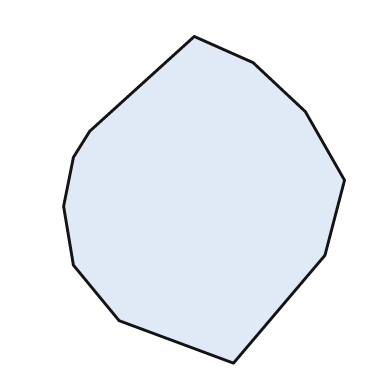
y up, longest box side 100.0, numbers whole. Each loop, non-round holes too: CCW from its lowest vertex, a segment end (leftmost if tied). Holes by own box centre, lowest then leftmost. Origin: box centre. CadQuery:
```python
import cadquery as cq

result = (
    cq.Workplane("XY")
    .moveTo(9.0, -50.0)
    .lineTo(37.0, -17.0)
    .lineTo(43.0, 6.0)
    .lineTo(31.0, 27.0)
    .lineTo(15.0, 42.0)
    .lineTo(-3.0, 50.0)
    .lineTo(-35.0, 21.0)
    .lineTo(-40.0, 13.0)
    .lineTo(-43.0, -2.0)
    .lineTo(-40.0, -20.0)
    .lineTo(-26.0, -37.0)
    .close()
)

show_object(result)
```